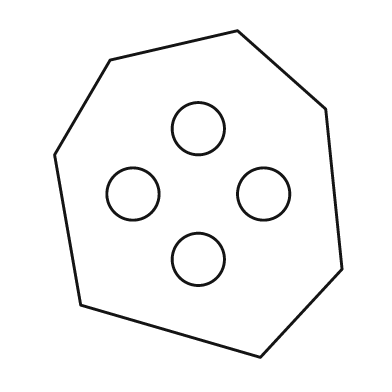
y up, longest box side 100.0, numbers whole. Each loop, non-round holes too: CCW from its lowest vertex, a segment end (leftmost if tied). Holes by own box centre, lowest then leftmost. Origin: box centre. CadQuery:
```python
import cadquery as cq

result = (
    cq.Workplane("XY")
    .moveTo(19.0, -50.0)
    .lineTo(44.0, -23.0)
    .lineTo(39.0, 26.0)
    .lineTo(12.0, 50.0)
    .lineTo(-27.0, 41.0)
    .lineTo(-44.0, 12.0)
    .lineTo(-36.0, -34.0)
    .close()
    .moveTo(0.0, -20.0)
    .circle(8.0)
    .moveTo(-20.0, 0.0)
    .circle(8.0)
    .moveTo(20.0, 0.0)
    .circle(8.0)
    .moveTo(0.0, 20.0)
    .circle(8.0)
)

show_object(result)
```